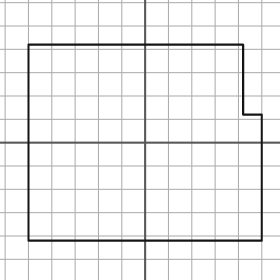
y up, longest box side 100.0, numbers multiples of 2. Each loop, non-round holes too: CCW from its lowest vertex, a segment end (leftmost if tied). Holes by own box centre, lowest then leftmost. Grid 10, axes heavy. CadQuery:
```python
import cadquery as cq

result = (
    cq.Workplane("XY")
    .moveTo(-50.0, -42.0)
    .lineTo(50.0, -42.0)
    .lineTo(50.0, 12.0)
    .lineTo(42.0, 12.0)
    .lineTo(42.0, 42.0)
    .lineTo(-50.0, 42.0)
    .close()
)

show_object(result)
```